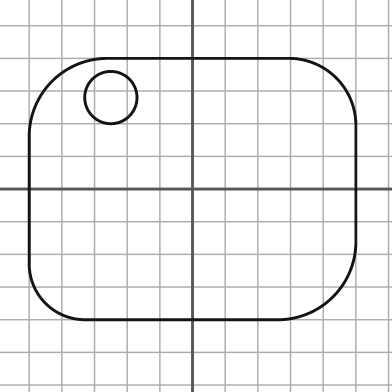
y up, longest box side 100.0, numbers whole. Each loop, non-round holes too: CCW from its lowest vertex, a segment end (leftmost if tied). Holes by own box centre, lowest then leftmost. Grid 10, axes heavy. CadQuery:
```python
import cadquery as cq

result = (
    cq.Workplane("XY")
    .moveTo(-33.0, -40.0)
    .lineTo(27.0, -40.0)
    .threePointArc((43.0, -33.0), (50.0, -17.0))
    .lineTo(50.0, 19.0)
    .threePointArc((44.0, 34.0), (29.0, 40.0))
    .lineTo(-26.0, 40.0)
    .threePointArc((-43.0, 33.0), (-50.0, 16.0))
    .lineTo(-50.0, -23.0)
    .threePointArc((-45.0, -35.0), (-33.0, -40.0))
    .close()
    .moveTo(-25.0, 28.0)
    .circle(8.0)
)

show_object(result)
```